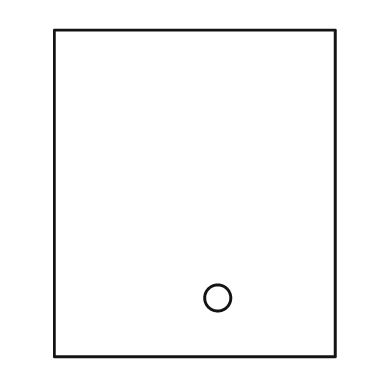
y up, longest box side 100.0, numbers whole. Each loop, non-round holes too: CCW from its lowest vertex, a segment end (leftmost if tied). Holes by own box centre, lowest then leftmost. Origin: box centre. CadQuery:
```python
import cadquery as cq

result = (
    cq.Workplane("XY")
    .moveTo(-43.0, -50.0)
    .lineTo(43.0, -50.0)
    .lineTo(43.0, 50.0)
    .lineTo(-43.0, 50.0)
    .close()
    .moveTo(7.0, -32.0)
    .circle(4.0)
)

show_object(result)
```